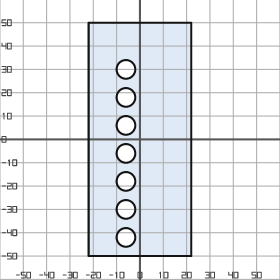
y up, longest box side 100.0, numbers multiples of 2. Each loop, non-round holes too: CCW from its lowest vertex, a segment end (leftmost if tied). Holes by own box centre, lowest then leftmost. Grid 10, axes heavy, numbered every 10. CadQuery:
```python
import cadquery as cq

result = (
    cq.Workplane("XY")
    .moveTo(-22.0, -50.0)
    .lineTo(22.0, -50.0)
    .lineTo(22.0, 50.0)
    .lineTo(-22.0, 50.0)
    .close()
    .moveTo(-6.0, -42.0)
    .circle(4.0)
    .moveTo(-6.0, -30.0)
    .circle(4.0)
    .moveTo(-6.0, -18.0)
    .circle(4.0)
    .moveTo(-6.0, -6.0)
    .circle(4.0)
    .moveTo(-6.0, 6.0)
    .circle(4.0)
    .moveTo(-6.0, 18.0)
    .circle(4.0)
    .moveTo(-6.0, 30.0)
    .circle(4.0)
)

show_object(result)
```